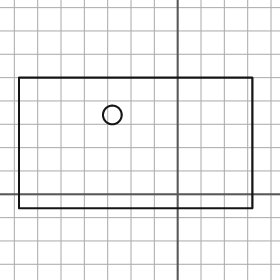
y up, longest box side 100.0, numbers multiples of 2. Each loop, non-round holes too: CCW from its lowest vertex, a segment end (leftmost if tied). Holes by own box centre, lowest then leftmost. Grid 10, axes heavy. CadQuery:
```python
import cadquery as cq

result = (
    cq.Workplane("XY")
    .moveTo(-68.0, -6.0)
    .lineTo(32.0, -6.0)
    .lineTo(32.0, 50.0)
    .lineTo(-68.0, 50.0)
    .close()
    .moveTo(-28.0, 34.0)
    .circle(4.0)
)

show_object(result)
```